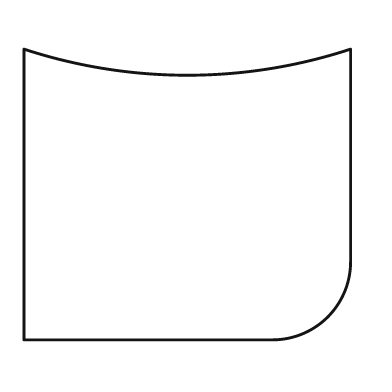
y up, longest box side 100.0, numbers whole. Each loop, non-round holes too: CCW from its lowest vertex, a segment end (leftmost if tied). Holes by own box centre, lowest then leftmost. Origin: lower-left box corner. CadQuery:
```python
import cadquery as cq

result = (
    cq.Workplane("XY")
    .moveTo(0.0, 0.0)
    .lineTo(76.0, 0.0)
    .threePointArc((93.0, 7.0), (100.0, 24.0))
    .lineTo(100.0, 89.0)
    .threePointArc((50.0, 81.0), (0.0, 89.0))
    .close()
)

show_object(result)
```